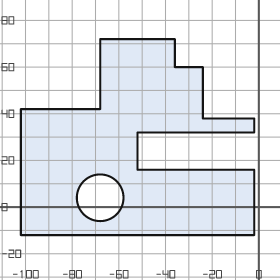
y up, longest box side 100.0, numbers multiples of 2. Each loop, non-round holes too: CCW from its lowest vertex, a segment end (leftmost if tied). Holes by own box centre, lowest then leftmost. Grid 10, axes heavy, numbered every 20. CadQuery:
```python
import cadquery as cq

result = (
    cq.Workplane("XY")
    .moveTo(-102.0, -12.0)
    .lineTo(-2.0, -12.0)
    .lineTo(-2.0, 16.0)
    .lineTo(-52.0, 16.0)
    .lineTo(-52.0, 32.0)
    .lineTo(-2.0, 32.0)
    .lineTo(-2.0, 38.0)
    .lineTo(-24.0, 38.0)
    .lineTo(-24.0, 60.0)
    .lineTo(-36.0, 60.0)
    .lineTo(-36.0, 72.0)
    .lineTo(-68.0, 72.0)
    .lineTo(-68.0, 42.0)
    .lineTo(-102.0, 42.0)
    .close()
    .moveTo(-68.0, 4.0)
    .circle(10.0)
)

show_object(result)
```